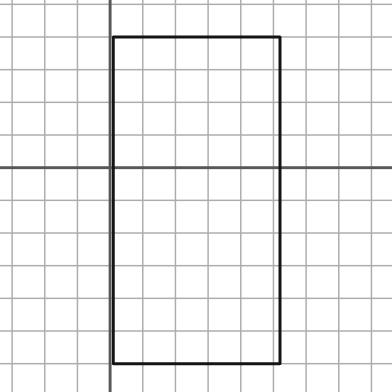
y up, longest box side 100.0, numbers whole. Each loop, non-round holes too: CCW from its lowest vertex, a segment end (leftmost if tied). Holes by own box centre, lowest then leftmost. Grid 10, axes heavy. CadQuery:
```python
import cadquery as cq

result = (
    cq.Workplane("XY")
    .moveTo(1.0, -60.0)
    .lineTo(52.0, -60.0)
    .lineTo(52.0, 40.0)
    .lineTo(1.0, 40.0)
    .close()
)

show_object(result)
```